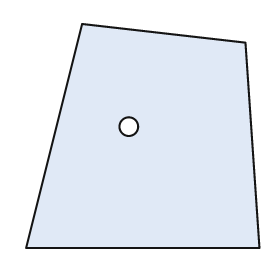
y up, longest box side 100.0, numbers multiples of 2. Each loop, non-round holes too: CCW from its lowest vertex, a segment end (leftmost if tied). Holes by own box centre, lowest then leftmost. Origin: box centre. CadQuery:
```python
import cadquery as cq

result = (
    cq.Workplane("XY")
    .moveTo(-50.0, -48.0)
    .lineTo(50.0, -48.0)
    .lineTo(44.0, 40.0)
    .lineTo(-26.0, 48.0)
    .close()
    .moveTo(-6.0, 4.0)
    .circle(4.0)
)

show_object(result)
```